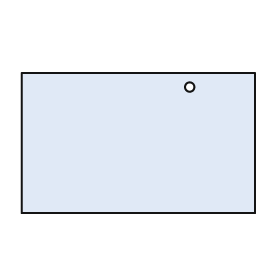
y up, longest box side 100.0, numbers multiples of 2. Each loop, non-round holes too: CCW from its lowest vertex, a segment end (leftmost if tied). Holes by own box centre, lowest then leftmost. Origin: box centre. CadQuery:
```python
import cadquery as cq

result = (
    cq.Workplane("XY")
    .moveTo(-50.0, -30.0)
    .lineTo(50.0, -30.0)
    .lineTo(50.0, 30.0)
    .lineTo(-50.0, 30.0)
    .close()
    .moveTo(22.0, 24.0)
    .circle(2.0)
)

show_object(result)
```